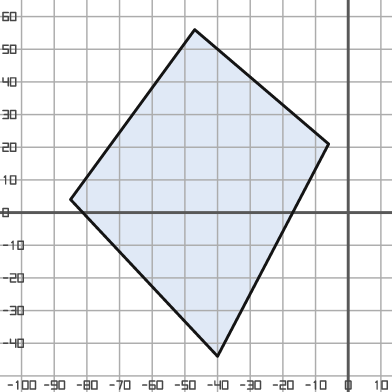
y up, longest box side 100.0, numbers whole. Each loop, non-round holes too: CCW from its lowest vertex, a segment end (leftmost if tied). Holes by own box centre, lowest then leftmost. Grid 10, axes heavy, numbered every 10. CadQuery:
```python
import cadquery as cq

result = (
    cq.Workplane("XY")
    .moveTo(-40.0, -44.0)
    .lineTo(-6.0, 21.0)
    .lineTo(-47.0, 56.0)
    .lineTo(-85.0, 4.0)
    .close()
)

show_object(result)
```